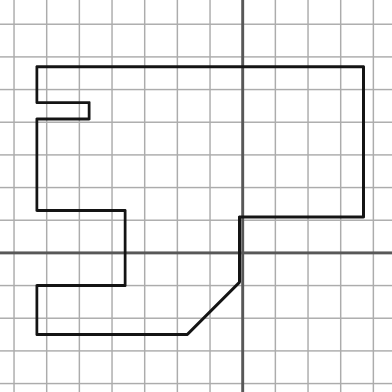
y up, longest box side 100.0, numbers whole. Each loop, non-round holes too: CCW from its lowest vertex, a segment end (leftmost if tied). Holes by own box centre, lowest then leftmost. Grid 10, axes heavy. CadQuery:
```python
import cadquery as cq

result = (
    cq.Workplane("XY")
    .moveTo(-63.0, -25.0)
    .lineTo(-17.0, -25.0)
    .lineTo(-1.0, -9.0)
    .lineTo(-1.0, 11.0)
    .lineTo(37.0, 11.0)
    .lineTo(37.0, 57.0)
    .lineTo(-63.0, 57.0)
    .lineTo(-63.0, 46.0)
    .lineTo(-47.0, 46.0)
    .lineTo(-47.0, 41.0)
    .lineTo(-63.0, 41.0)
    .lineTo(-63.0, 13.0)
    .lineTo(-36.0, 13.0)
    .lineTo(-36.0, -10.0)
    .lineTo(-63.0, -10.0)
    .close()
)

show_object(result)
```